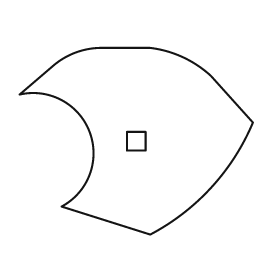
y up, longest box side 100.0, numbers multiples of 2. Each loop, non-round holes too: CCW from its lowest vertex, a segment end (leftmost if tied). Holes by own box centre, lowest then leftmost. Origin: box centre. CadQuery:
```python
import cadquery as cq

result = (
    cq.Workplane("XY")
    .moveTo(6.0, -40.0)
    .threePointArc((32.0, -20.0), (50.0, 8.0))
    .lineTo(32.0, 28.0)
    .threePointArc((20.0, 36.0), (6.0, 40.0))
    .lineTo(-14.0, 40.0)
    .threePointArc((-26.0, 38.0), (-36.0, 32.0))
    .lineTo(-50.0, 20.0)
    .threePointArc((-20.0, 4.0), (-32.0, -28.0))
    .close()
    .moveTo(-4.0, -4.0)
    .lineTo(4.0, -4.0)
    .lineTo(4.0, 4.0)
    .lineTo(-4.0, 4.0)
    .close()
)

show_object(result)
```